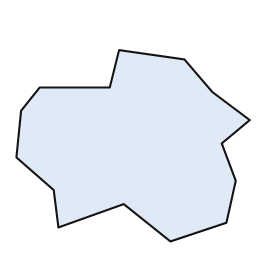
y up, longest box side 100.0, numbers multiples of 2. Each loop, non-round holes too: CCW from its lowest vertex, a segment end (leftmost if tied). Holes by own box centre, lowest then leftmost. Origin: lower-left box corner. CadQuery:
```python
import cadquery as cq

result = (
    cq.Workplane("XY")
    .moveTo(66.0, 0.0)
    .lineTo(90.0, 8.0)
    .lineTo(94.0, 26.0)
    .lineTo(88.0, 42.0)
    .lineTo(100.0, 52.0)
    .lineTo(84.0, 64.0)
    .lineTo(72.0, 78.0)
    .lineTo(44.0, 82.0)
    .lineTo(40.0, 66.0)
    .lineTo(10.0, 66.0)
    .lineTo(2.0, 56.0)
    .lineTo(0.0, 36.0)
    .lineTo(16.0, 22.0)
    .lineTo(18.0, 6.0)
    .lineTo(46.0, 16.0)
    .close()
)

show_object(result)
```